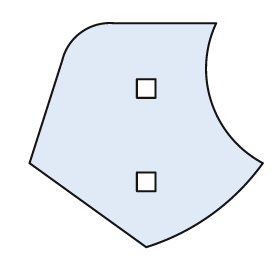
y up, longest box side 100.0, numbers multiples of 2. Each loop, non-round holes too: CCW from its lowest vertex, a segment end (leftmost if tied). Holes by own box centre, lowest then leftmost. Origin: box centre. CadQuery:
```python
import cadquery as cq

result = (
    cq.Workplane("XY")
    .moveTo(0.0, -48.0)
    .threePointArc((28.0, -34.0), (50.0, -12.0))
    .threePointArc((28.0, 14.0), (30.0, 48.0))
    .lineTo(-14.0, 48.0)
    .threePointArc((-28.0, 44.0), (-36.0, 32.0))
    .lineTo(-50.0, -12.0)
    .close()
    .moveTo(-4.0, -24.0)
    .lineTo(4.0, -24.0)
    .lineTo(4.0, -16.0)
    .lineTo(-4.0, -16.0)
    .close()
    .moveTo(-4.0, 16.0)
    .lineTo(4.0, 16.0)
    .lineTo(4.0, 24.0)
    .lineTo(-4.0, 24.0)
    .close()
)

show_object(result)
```